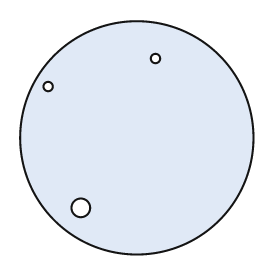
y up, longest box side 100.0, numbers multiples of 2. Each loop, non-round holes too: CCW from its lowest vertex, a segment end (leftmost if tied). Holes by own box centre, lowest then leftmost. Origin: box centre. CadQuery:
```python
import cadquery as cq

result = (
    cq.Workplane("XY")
    .moveTo(0.0, 0.0)
    .circle(50.0)
    .moveTo(-24.0, -30.0)
    .circle(4.0)
    .moveTo(-38.0, 22.0)
    .circle(2.0)
    .moveTo(8.0, 34.0)
    .circle(2.0)
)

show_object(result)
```